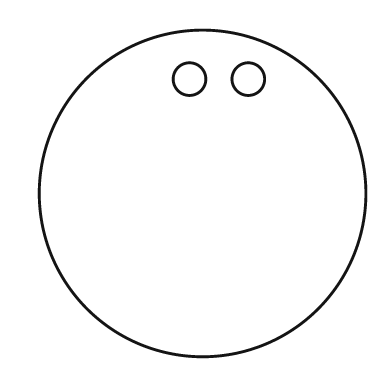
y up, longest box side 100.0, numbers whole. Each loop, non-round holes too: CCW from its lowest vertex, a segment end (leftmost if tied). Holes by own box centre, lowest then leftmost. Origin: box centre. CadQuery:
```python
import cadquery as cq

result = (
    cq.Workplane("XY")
    .moveTo(0.0, 0.0)
    .circle(50.0)
    .moveTo(-4.0, 35.0)
    .circle(5.0)
    .moveTo(14.0, 35.0)
    .circle(5.0)
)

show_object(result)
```